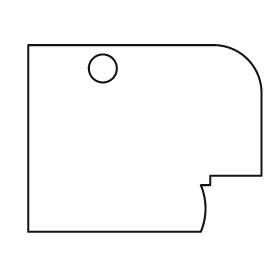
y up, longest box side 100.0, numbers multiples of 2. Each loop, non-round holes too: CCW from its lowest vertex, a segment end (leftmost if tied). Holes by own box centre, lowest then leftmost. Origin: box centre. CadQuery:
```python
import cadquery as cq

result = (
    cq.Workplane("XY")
    .moveTo(-50.0, -40.0)
    .lineTo(24.0, -40.0)
    .threePointArc((26.0, -30.0), (24.0, -20.0))
    .lineTo(28.0, -20.0)
    .lineTo(28.0, -16.0)
    .lineTo(50.0, -16.0)
    .lineTo(50.0, 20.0)
    .threePointArc((44.0, 34.0), (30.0, 40.0))
    .lineTo(-50.0, 40.0)
    .close()
    .moveTo(-18.0, 30.0)
    .circle(6.0)
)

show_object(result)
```